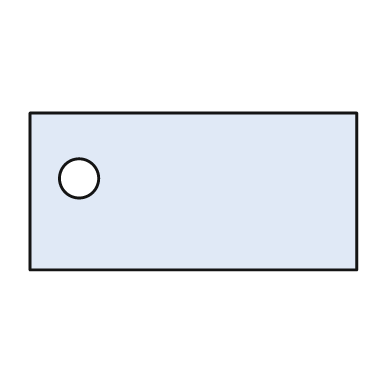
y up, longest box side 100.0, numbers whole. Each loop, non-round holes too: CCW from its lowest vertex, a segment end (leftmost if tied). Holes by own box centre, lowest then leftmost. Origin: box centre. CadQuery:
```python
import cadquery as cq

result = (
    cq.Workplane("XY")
    .moveTo(-50.0, -24.0)
    .lineTo(50.0, -24.0)
    .lineTo(50.0, 24.0)
    .lineTo(-50.0, 24.0)
    .close()
    .moveTo(-35.0, 4.0)
    .circle(6.0)
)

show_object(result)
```